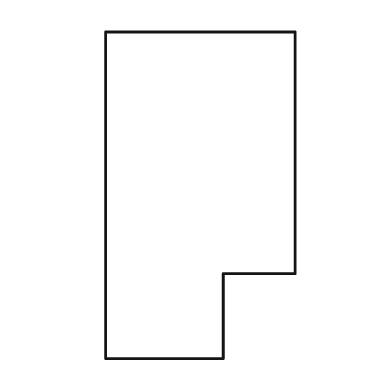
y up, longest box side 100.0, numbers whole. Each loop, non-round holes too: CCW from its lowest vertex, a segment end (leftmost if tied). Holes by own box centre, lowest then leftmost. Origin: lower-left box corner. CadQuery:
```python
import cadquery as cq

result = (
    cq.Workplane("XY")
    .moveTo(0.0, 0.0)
    .lineTo(36.0, 0.0)
    .lineTo(36.0, 26.0)
    .lineTo(58.0, 26.0)
    .lineTo(58.0, 100.0)
    .lineTo(0.0, 100.0)
    .close()
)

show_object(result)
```